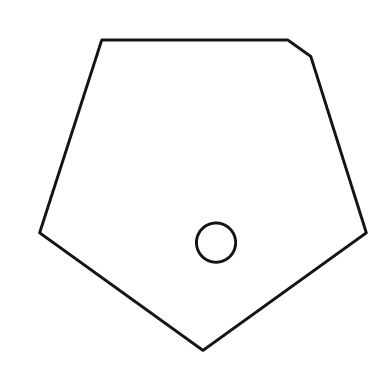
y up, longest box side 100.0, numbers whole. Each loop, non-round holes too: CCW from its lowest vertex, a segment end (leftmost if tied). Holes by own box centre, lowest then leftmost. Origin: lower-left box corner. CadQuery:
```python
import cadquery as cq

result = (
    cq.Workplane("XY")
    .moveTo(50.0, 0.0)
    .lineTo(100.0, 36.0)
    .lineTo(83.0, 90.0)
    .lineTo(76.0, 95.0)
    .lineTo(19.0, 95.0)
    .lineTo(0.0, 36.0)
    .close()
    .moveTo(54.0, 33.0)
    .circle(6.0)
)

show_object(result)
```